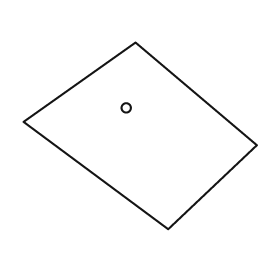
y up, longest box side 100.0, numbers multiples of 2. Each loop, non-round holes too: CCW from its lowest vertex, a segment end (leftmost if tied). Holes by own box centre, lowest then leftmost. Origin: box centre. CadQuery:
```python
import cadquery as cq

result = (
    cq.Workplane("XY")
    .moveTo(12.0, -40.0)
    .lineTo(50.0, -4.0)
    .lineTo(-2.0, 40.0)
    .lineTo(-50.0, 6.0)
    .close()
    .moveTo(-6.0, 12.0)
    .circle(2.0)
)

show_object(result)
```